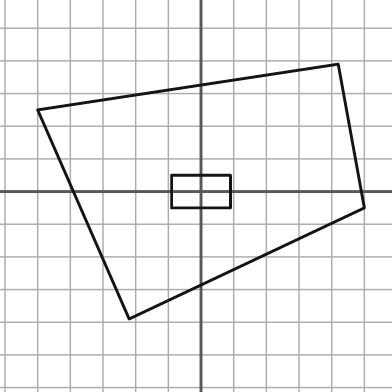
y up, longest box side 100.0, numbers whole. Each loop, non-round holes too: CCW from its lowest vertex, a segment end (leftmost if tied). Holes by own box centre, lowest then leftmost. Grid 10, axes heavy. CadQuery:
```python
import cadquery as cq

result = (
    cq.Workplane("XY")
    .moveTo(-22.0, -39.0)
    .lineTo(50.0, -5.0)
    .lineTo(42.0, 39.0)
    .lineTo(-50.0, 25.0)
    .close()
    .moveTo(-9.0, -5.0)
    .lineTo(9.0, -5.0)
    .lineTo(9.0, 5.0)
    .lineTo(-9.0, 5.0)
    .close()
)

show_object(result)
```